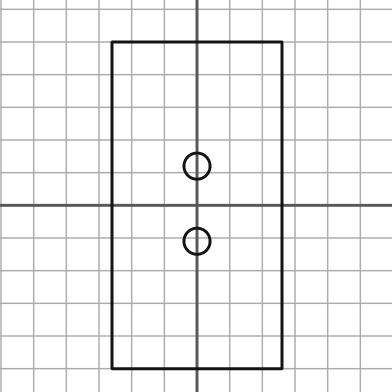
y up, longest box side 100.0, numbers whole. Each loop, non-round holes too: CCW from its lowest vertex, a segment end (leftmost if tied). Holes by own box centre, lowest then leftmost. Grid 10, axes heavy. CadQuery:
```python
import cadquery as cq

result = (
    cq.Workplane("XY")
    .moveTo(-26.0, -50.0)
    .lineTo(26.0, -50.0)
    .lineTo(26.0, 50.0)
    .lineTo(-26.0, 50.0)
    .close()
    .moveTo(0.0, -11.0)
    .circle(4.0)
    .moveTo(0.0, 12.0)
    .circle(4.0)
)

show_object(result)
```